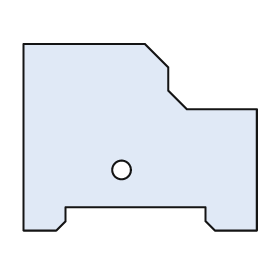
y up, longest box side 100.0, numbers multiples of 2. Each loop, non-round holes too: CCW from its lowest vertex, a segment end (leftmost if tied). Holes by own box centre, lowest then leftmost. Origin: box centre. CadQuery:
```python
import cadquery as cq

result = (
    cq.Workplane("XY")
    .moveTo(-50.0, -40.0)
    .lineTo(-36.0, -40.0)
    .lineTo(-32.0, -36.0)
    .lineTo(-32.0, -30.0)
    .lineTo(28.0, -30.0)
    .lineTo(28.0, -36.0)
    .lineTo(32.0, -40.0)
    .lineTo(50.0, -40.0)
    .lineTo(50.0, 12.0)
    .lineTo(20.0, 12.0)
    .lineTo(12.0, 20.0)
    .lineTo(12.0, 30.0)
    .lineTo(2.0, 40.0)
    .lineTo(-50.0, 40.0)
    .close()
    .moveTo(-8.0, -14.0)
    .circle(4.0)
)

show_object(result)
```